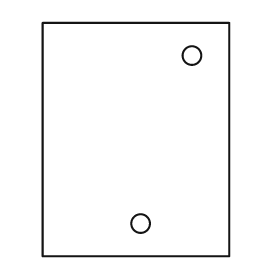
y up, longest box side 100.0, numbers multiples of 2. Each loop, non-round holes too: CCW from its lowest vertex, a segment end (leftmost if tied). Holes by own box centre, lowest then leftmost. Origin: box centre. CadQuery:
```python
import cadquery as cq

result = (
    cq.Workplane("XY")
    .moveTo(-40.0, -50.0)
    .lineTo(40.0, -50.0)
    .lineTo(40.0, 50.0)
    .lineTo(-40.0, 50.0)
    .close()
    .moveTo(2.0, -36.0)
    .circle(4.0)
    .moveTo(24.0, 36.0)
    .circle(4.0)
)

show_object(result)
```